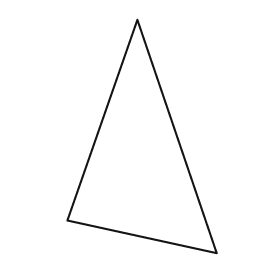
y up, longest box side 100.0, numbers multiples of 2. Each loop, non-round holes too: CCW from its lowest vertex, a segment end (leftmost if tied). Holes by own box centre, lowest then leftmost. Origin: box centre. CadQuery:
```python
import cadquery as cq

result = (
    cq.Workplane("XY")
    .moveTo(32.0, -50.0)
    .lineTo(-2.0, 50.0)
    .lineTo(-32.0, -36.0)
    .close()
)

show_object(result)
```